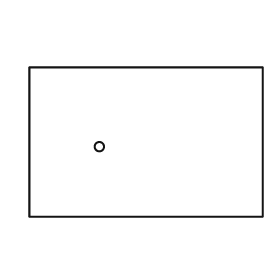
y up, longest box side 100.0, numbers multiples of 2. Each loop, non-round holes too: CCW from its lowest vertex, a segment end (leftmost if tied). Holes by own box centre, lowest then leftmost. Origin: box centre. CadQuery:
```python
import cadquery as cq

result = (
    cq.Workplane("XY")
    .moveTo(-50.0, -32.0)
    .lineTo(50.0, -32.0)
    .lineTo(50.0, 32.0)
    .lineTo(-50.0, 32.0)
    .close()
    .moveTo(-20.0, -2.0)
    .circle(2.0)
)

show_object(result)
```